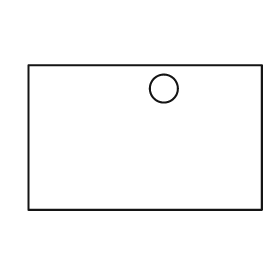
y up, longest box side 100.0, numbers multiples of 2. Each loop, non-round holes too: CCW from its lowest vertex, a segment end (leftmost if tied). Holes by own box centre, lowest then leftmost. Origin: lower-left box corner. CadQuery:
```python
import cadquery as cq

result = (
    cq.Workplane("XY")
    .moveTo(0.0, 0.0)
    .lineTo(100.0, 0.0)
    .lineTo(100.0, 62.0)
    .lineTo(0.0, 62.0)
    .close()
    .moveTo(58.0, 52.0)
    .circle(6.0)
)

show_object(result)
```